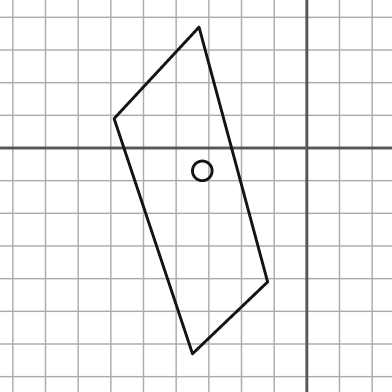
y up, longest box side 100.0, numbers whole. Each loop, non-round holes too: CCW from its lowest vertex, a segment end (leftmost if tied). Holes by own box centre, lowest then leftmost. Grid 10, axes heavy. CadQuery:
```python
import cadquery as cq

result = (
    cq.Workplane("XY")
    .moveTo(-35.0, -63.0)
    .lineTo(-12.0, -41.0)
    .lineTo(-33.0, 37.0)
    .lineTo(-59.0, 9.0)
    .close()
    .moveTo(-32.0, -7.0)
    .circle(3.0)
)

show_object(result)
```